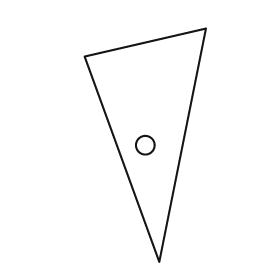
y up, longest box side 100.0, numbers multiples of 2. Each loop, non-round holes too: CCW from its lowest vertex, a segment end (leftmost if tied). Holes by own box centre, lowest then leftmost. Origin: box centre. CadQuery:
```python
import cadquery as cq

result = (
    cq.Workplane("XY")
    .moveTo(6.0, -50.0)
    .lineTo(26.0, 50.0)
    .lineTo(-26.0, 38.0)
    .close()
    .moveTo(0.0, 0.0)
    .circle(4.0)
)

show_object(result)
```